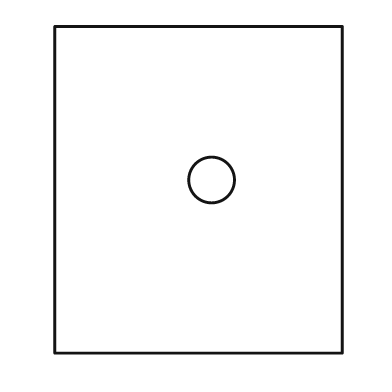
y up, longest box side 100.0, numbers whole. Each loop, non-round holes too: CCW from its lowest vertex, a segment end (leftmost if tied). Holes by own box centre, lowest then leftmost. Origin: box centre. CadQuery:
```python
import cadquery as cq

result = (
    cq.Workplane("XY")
    .moveTo(-44.0, -50.0)
    .lineTo(44.0, -50.0)
    .lineTo(44.0, 50.0)
    .lineTo(-44.0, 50.0)
    .close()
    .moveTo(4.0, 3.0)
    .circle(7.0)
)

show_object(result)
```